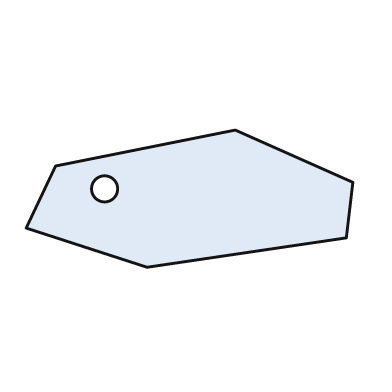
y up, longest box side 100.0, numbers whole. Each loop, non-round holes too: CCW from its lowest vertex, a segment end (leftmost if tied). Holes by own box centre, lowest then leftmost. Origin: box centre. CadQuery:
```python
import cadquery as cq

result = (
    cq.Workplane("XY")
    .moveTo(-13.0, -21.0)
    .lineTo(48.0, -12.0)
    .lineTo(50.0, 5.0)
    .lineTo(14.0, 21.0)
    .lineTo(-41.0, 10.0)
    .lineTo(-50.0, -9.0)
    .close()
    .moveTo(-26.0, 3.0)
    .circle(4.0)
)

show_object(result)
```